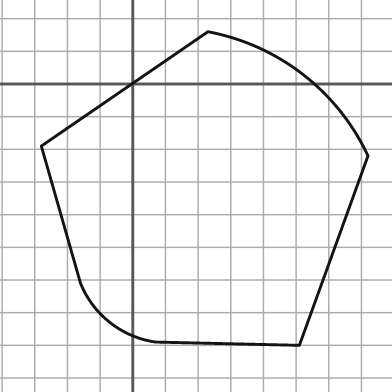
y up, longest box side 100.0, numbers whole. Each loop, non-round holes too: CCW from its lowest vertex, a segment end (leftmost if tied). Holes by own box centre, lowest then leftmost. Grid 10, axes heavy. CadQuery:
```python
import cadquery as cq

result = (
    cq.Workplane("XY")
    .moveTo(51.0, -80.0)
    .lineTo(72.0, -22.0)
    .threePointArc((52.0, 3.0), (23.0, 16.0))
    .lineTo(-28.0, -19.0)
    .lineTo(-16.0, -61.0)
    .threePointArc((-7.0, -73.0), (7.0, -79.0))
    .close()
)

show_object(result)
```